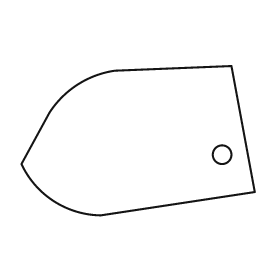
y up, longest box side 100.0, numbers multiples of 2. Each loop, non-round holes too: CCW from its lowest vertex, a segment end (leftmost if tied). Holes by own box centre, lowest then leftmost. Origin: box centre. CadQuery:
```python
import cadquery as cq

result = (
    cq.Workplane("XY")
    .moveTo(-16.0, -32.0)
    .lineTo(50.0, -22.0)
    .lineTo(40.0, 32.0)
    .lineTo(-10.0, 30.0)
    .threePointArc((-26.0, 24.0), (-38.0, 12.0))
    .lineTo(-50.0, -10.0)
    .threePointArc((-36.0, -26.0), (-16.0, -32.0))
    .close()
    .moveTo(36.0, -6.0)
    .circle(4.0)
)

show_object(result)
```